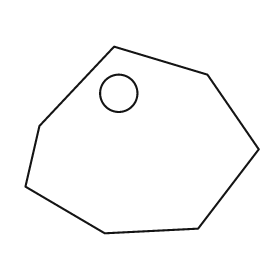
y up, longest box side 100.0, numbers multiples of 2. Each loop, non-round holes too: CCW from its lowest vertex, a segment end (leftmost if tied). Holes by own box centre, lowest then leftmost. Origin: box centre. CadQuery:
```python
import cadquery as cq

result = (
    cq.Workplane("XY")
    .moveTo(-16.0, -40.0)
    .lineTo(24.0, -38.0)
    .lineTo(50.0, -4.0)
    .lineTo(28.0, 28.0)
    .lineTo(-12.0, 40.0)
    .lineTo(-44.0, 6.0)
    .lineTo(-50.0, -20.0)
    .close()
    .moveTo(-10.0, 20.0)
    .circle(8.0)
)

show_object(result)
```